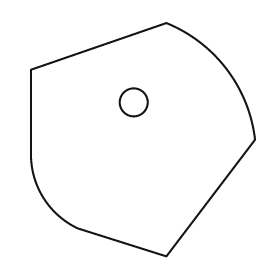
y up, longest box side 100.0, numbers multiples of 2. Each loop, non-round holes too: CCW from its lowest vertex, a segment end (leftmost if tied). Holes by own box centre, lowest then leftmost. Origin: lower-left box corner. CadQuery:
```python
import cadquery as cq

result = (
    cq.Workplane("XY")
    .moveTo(58.0, 0.0)
    .lineTo(96.0, 50.0)
    .threePointArc((84.0, 80.0), (58.0, 100.0))
    .lineTo(0.0, 80.0)
    .lineTo(0.0, 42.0)
    .threePointArc((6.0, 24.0), (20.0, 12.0))
    .close()
    .moveTo(44.0, 66.0)
    .circle(6.0)
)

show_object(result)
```